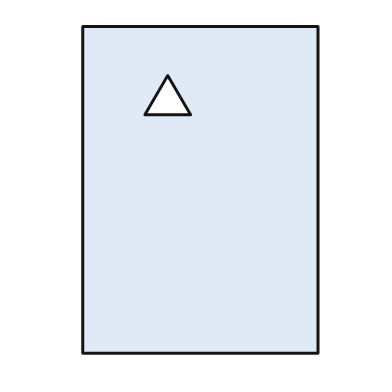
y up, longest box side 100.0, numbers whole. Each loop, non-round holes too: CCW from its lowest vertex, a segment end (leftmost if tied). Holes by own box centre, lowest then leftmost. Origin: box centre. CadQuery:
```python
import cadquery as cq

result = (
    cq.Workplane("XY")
    .moveTo(-36.0, -50.0)
    .lineTo(36.0, -50.0)
    .lineTo(36.0, 50.0)
    .lineTo(-36.0, 50.0)
    .close()
    .moveTo(-17.0, 23.0)
    .lineTo(-3.0, 23.0)
    .lineTo(-10.0, 35.0)
    .close()
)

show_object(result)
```